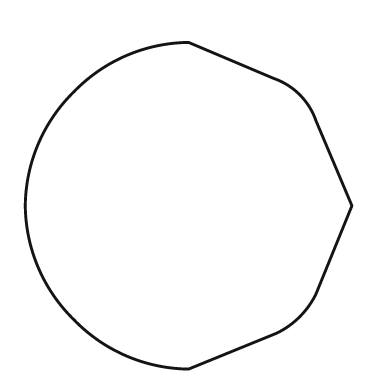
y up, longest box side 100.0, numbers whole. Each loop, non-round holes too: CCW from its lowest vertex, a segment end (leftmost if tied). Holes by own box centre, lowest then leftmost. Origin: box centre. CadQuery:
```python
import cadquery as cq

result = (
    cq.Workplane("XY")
    .moveTo(0.0, -50.0)
    .lineTo(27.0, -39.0)
    .threePointArc((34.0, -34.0), (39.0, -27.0))
    .lineTo(50.0, 0.0)
    .lineTo(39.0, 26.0)
    .threePointArc((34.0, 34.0), (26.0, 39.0))
    .lineTo(0.0, 50.0)
    .threePointArc((-19.0, 46.0), (-35.0, 35.0))
    .threePointArc((-46.0, 19.0), (-50.0, 0.0))
    .threePointArc((-46.0, -19.0), (-35.0, -35.0))
    .threePointArc((-19.0, -46.0), (0.0, -50.0))
    .close()
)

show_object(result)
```